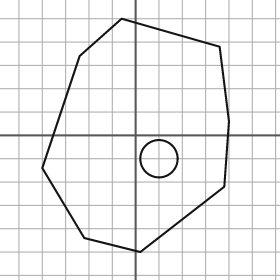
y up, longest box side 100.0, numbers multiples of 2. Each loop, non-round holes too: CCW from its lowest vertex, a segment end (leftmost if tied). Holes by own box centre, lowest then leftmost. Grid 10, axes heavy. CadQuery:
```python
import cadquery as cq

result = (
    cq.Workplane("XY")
    .moveTo(2.0, -50.0)
    .lineTo(38.0, -22.0)
    .lineTo(40.0, 6.0)
    .lineTo(36.0, 38.0)
    .lineTo(-6.0, 50.0)
    .lineTo(-24.0, 34.0)
    .lineTo(-40.0, -14.0)
    .lineTo(-22.0, -44.0)
    .close()
    .moveTo(10.0, -10.0)
    .circle(8.0)
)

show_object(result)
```